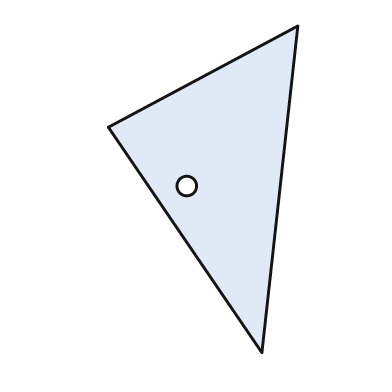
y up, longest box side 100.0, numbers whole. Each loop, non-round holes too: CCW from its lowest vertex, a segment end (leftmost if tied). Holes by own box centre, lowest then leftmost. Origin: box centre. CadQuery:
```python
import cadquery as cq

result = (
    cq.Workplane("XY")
    .moveTo(18.0, -50.0)
    .lineTo(29.0, 50.0)
    .lineTo(-29.0, 19.0)
    .close()
    .moveTo(-5.0, 1.0)
    .circle(3.0)
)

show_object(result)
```